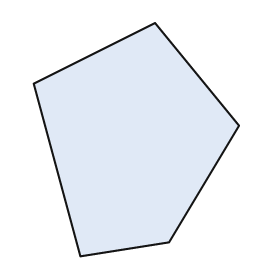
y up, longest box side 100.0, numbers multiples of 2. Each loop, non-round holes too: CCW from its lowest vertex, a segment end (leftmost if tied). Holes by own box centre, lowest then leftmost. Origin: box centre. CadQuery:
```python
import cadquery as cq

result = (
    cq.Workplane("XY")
    .moveTo(-24.0, -50.0)
    .lineTo(14.0, -44.0)
    .lineTo(44.0, 6.0)
    .lineTo(8.0, 50.0)
    .lineTo(-44.0, 24.0)
    .close()
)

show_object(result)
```